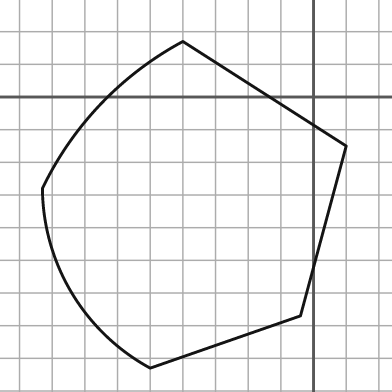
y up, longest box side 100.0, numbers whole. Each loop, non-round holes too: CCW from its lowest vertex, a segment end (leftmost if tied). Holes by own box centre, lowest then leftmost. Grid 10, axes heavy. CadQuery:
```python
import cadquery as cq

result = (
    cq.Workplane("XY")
    .moveTo(-50.0, -83.0)
    .lineTo(-4.0, -67.0)
    .lineTo(10.0, -15.0)
    .lineTo(-40.0, 17.0)
    .threePointArc((-65.0, -2.0), (-83.0, -28.0))
    .threePointArc((-74.0, -60.0), (-50.0, -83.0))
    .close()
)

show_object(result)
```